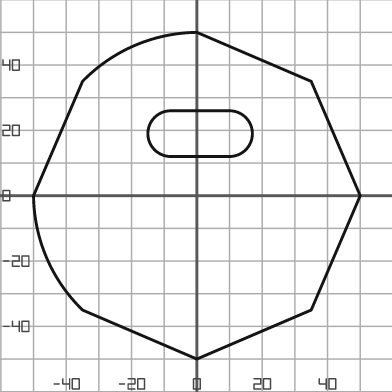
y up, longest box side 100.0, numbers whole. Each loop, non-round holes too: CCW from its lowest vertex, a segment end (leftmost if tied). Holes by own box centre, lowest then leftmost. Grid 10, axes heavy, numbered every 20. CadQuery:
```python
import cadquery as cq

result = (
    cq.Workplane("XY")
    .moveTo(0.0, -50.0)
    .lineTo(35.0, -35.0)
    .lineTo(50.0, 0.0)
    .lineTo(35.0, 35.0)
    .lineTo(0.0, 50.0)
    .threePointArc((-19.0, 46.0), (-35.0, 35.0))
    .lineTo(-50.0, 0.0)
    .threePointArc((-46.0, -19.0), (-35.0, -35.0))
    .close()
    .moveTo(-8.0, 12.0)
    .lineTo(10.0, 12.0)
    .threePointArc((17.0, 19.0), (10.0, 26.0))
    .lineTo(-8.0, 26.0)
    .threePointArc((-15.0, 19.0), (-8.0, 12.0))
    .close()
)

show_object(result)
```